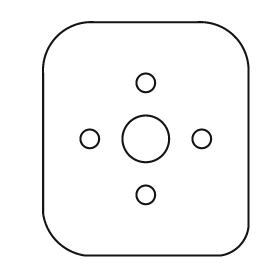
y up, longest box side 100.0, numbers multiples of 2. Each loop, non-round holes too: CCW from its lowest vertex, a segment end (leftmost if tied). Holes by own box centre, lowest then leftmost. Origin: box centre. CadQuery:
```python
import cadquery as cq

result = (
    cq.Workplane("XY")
    .moveTo(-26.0, -50.0)
    .lineTo(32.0, -50.0)
    .threePointArc((40.0, -46.0), (44.0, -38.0))
    .lineTo(44.0, 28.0)
    .threePointArc((38.0, 44.0), (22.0, 50.0))
    .lineTo(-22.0, 50.0)
    .threePointArc((-38.0, 44.0), (-44.0, 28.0))
    .lineTo(-44.0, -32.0)
    .threePointArc((-38.0, -44.0), (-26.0, -50.0))
    .close()
    .moveTo(0.0, -24.0)
    .circle(4.0)
    .moveTo(-24.0, 0.0)
    .circle(4.0)
    .moveTo(0.0, 0.0)
    .circle(10.0)
    .moveTo(24.0, 0.0)
    .circle(4.0)
    .moveTo(0.0, 24.0)
    .circle(4.0)
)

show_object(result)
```